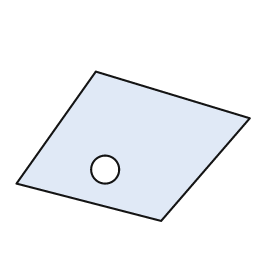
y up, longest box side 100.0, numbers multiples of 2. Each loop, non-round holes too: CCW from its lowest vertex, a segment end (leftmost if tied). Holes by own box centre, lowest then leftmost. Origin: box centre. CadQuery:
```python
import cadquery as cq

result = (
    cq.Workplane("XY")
    .moveTo(12.0, -32.0)
    .lineTo(50.0, 12.0)
    .lineTo(-16.0, 32.0)
    .lineTo(-50.0, -16.0)
    .close()
    .moveTo(-12.0, -10.0)
    .circle(6.0)
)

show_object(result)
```